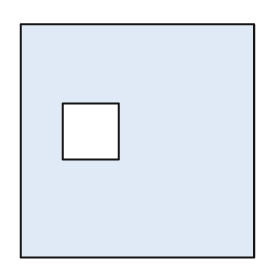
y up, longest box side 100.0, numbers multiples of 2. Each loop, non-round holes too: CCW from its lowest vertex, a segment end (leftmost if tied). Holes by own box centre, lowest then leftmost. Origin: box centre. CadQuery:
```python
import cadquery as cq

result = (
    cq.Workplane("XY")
    .moveTo(-50.0, -50.0)
    .lineTo(50.0, -50.0)
    .lineTo(50.0, 50.0)
    .lineTo(-50.0, 50.0)
    .close()
    .moveTo(-32.0, -8.0)
    .lineTo(-8.0, -8.0)
    .lineTo(-8.0, 16.0)
    .lineTo(-32.0, 16.0)
    .close()
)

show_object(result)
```